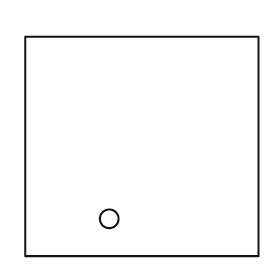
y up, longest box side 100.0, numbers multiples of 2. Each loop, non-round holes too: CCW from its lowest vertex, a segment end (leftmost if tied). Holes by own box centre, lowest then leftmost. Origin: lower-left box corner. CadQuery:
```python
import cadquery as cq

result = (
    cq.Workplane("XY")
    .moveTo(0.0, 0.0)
    .lineTo(100.0, 0.0)
    .lineTo(100.0, 94.0)
    .lineTo(0.0, 94.0)
    .close()
    .moveTo(36.0, 16.0)
    .circle(4.0)
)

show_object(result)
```